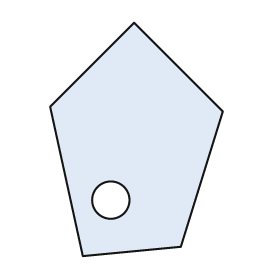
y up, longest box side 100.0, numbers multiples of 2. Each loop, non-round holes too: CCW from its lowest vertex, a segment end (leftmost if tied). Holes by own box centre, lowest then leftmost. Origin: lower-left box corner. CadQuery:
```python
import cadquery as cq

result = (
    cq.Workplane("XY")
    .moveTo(14.0, 0.0)
    .lineTo(56.0, 4.0)
    .lineTo(74.0, 62.0)
    .lineTo(36.0, 100.0)
    .lineTo(0.0, 64.0)
    .close()
    .moveTo(26.0, 24.0)
    .circle(8.0)
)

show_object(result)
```